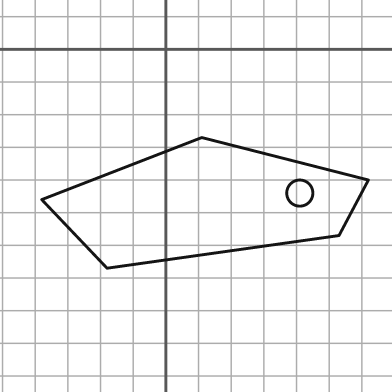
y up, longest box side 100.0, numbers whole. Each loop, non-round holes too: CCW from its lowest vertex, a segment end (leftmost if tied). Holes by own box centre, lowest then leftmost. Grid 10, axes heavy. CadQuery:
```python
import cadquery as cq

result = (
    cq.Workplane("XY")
    .moveTo(-18.0, -67.0)
    .lineTo(53.0, -57.0)
    .lineTo(62.0, -40.0)
    .lineTo(11.0, -27.0)
    .lineTo(-38.0, -46.0)
    .close()
    .moveTo(41.0, -44.0)
    .circle(4.0)
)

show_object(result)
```